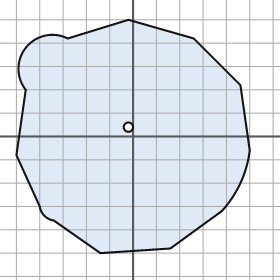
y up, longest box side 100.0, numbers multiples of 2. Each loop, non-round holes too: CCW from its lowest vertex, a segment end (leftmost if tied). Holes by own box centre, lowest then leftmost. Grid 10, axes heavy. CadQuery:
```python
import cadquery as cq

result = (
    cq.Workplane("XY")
    .moveTo(-14.0, -50.0)
    .lineTo(16.0, -48.0)
    .lineTo(38.0, -32.0)
    .threePointArc((46.0, -20.0), (50.0, -6.0))
    .lineTo(46.0, 22.0)
    .lineTo(26.0, 42.0)
    .lineTo(-2.0, 50.0)
    .lineTo(-28.0, 42.0)
    .threePointArc((-46.0, 38.0), (-46.0, 20.0))
    .lineTo(-50.0, -8.0)
    .lineTo(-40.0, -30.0)
    .threePointArc((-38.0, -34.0), (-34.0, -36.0))
    .close()
    .moveTo(-2.0, 4.0)
    .circle(2.0)
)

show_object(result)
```